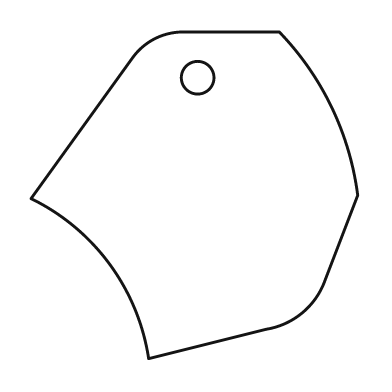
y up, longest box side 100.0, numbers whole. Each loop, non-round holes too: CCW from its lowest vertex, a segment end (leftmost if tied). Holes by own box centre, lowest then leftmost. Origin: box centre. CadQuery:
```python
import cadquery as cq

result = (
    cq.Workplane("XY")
    .moveTo(-14.0, -50.0)
    .lineTo(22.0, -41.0)
    .threePointArc((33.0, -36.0), (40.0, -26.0))
    .lineTo(50.0, 0.0)
    .threePointArc((42.0, 27.0), (26.0, 50.0))
    .lineTo(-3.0, 50.0)
    .threePointArc((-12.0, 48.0), (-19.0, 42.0))
    .lineTo(-50.0, -1.0)
    .threePointArc((-26.0, -21.0), (-14.0, -50.0))
    .close()
    .moveTo(1.0, 36.0)
    .circle(5.0)
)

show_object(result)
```